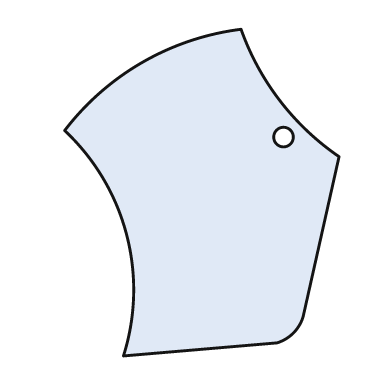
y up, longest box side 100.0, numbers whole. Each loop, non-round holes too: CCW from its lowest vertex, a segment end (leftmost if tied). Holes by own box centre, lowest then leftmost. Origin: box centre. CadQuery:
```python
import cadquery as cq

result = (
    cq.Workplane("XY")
    .moveTo(-24.0, -50.0)
    .lineTo(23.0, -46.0)
    .threePointArc((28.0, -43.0), (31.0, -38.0))
    .lineTo(42.0, 11.0)
    .threePointArc((24.0, 28.0), (12.0, 50.0))
    .threePointArc((-18.0, 40.0), (-42.0, 19.0))
    .threePointArc((-23.0, -13.0), (-24.0, -50.0))
    .close()
    .moveTo(25.0, 17.0)
    .circle(3.0)
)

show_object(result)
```